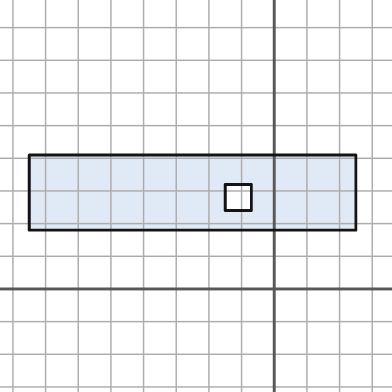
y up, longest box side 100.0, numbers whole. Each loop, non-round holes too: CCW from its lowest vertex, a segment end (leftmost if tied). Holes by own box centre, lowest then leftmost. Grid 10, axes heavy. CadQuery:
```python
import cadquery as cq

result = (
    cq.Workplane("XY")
    .moveTo(-75.0, 18.0)
    .lineTo(25.0, 18.0)
    .lineTo(25.0, 41.0)
    .lineTo(-75.0, 41.0)
    .close()
    .moveTo(-15.0, 24.0)
    .lineTo(-7.0, 24.0)
    .lineTo(-7.0, 32.0)
    .lineTo(-15.0, 32.0)
    .close()
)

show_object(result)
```